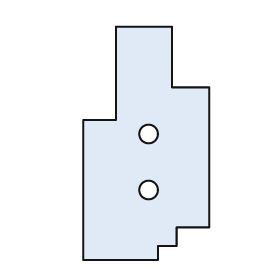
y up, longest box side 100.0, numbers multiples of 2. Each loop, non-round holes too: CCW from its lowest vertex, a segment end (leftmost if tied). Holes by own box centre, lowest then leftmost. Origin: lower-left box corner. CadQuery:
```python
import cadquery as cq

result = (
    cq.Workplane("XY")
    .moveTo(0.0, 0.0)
    .lineTo(32.0, 0.0)
    .lineTo(32.0, 6.0)
    .lineTo(40.0, 6.0)
    .lineTo(40.0, 14.0)
    .lineTo(54.0, 14.0)
    .lineTo(54.0, 74.0)
    .lineTo(38.0, 74.0)
    .lineTo(38.0, 100.0)
    .lineTo(14.0, 100.0)
    .lineTo(14.0, 60.0)
    .lineTo(0.0, 60.0)
    .close()
    .moveTo(28.0, 30.0)
    .circle(4.0)
    .moveTo(28.0, 54.0)
    .circle(4.0)
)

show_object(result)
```